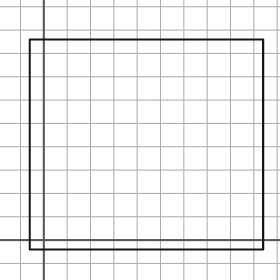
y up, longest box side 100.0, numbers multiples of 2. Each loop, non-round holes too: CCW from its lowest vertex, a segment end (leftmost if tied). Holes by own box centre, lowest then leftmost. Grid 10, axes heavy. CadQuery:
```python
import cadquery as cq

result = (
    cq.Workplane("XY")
    .moveTo(-6.0, -4.0)
    .lineTo(94.0, -4.0)
    .lineTo(94.0, 86.0)
    .lineTo(-6.0, 86.0)
    .close()
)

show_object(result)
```